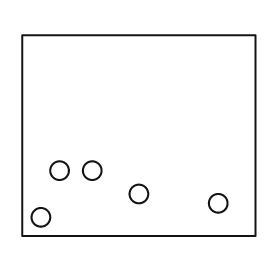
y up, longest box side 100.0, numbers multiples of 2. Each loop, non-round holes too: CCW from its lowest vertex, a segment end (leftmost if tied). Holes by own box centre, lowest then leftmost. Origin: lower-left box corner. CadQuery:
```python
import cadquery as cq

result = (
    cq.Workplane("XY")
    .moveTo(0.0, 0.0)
    .lineTo(100.0, 0.0)
    .lineTo(100.0, 86.0)
    .lineTo(0.0, 86.0)
    .close()
    .moveTo(8.0, 8.0)
    .circle(4.0)
    .moveTo(84.0, 14.0)
    .circle(4.0)
    .moveTo(50.0, 18.0)
    .circle(4.0)
    .moveTo(16.0, 28.0)
    .circle(4.0)
    .moveTo(30.0, 28.0)
    .circle(4.0)
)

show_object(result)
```